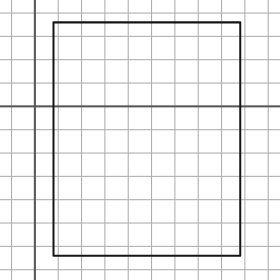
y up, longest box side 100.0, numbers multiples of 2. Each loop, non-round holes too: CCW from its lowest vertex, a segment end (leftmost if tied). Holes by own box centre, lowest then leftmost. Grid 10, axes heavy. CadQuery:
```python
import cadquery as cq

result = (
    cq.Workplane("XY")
    .moveTo(8.0, -64.0)
    .lineTo(88.0, -64.0)
    .lineTo(88.0, 36.0)
    .lineTo(8.0, 36.0)
    .close()
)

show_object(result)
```